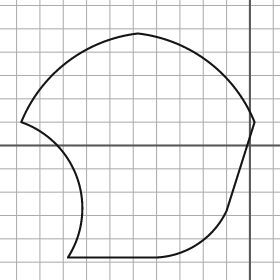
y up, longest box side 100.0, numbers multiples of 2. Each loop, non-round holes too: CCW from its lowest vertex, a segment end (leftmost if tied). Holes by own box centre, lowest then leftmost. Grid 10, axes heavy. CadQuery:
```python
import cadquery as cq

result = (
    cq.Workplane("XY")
    .moveTo(-78.0, -48.0)
    .lineTo(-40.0, -48.0)
    .threePointArc((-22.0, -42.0), (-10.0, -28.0))
    .lineTo(2.0, 10.0)
    .threePointArc((-18.0, 36.0), (-48.0, 48.0))
    .threePointArc((-78.0, 36.0), (-98.0, 10.0))
    .threePointArc((-74.0, -14.0), (-78.0, -48.0))
    .close()
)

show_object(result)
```